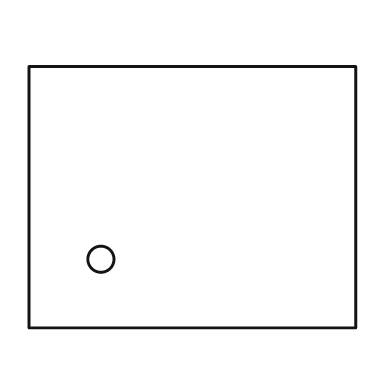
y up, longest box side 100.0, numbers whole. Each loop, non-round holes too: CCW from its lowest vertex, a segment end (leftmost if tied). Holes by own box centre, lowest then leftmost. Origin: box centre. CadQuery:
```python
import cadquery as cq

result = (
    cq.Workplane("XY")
    .moveTo(-50.0, -40.0)
    .lineTo(50.0, -40.0)
    .lineTo(50.0, 40.0)
    .lineTo(-50.0, 40.0)
    .close()
    .moveTo(-28.0, -19.0)
    .circle(4.0)
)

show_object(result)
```